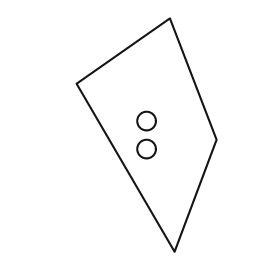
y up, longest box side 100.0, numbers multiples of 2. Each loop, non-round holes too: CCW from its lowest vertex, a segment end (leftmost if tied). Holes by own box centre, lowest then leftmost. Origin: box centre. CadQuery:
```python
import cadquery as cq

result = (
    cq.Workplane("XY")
    .moveTo(12.0, -50.0)
    .lineTo(30.0, -2.0)
    .lineTo(10.0, 50.0)
    .lineTo(-30.0, 22.0)
    .close()
    .moveTo(0.0, -6.0)
    .circle(4.0)
    .moveTo(0.0, 6.0)
    .circle(4.0)
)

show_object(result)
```